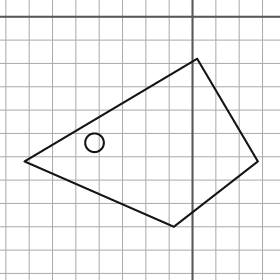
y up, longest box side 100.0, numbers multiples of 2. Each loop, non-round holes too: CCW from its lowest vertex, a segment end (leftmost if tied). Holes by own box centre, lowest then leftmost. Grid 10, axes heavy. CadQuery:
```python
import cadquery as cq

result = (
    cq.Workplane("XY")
    .moveTo(-8.0, -90.0)
    .lineTo(28.0, -62.0)
    .lineTo(2.0, -18.0)
    .lineTo(-72.0, -62.0)
    .close()
    .moveTo(-42.0, -54.0)
    .circle(4.0)
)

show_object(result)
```